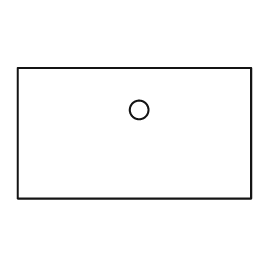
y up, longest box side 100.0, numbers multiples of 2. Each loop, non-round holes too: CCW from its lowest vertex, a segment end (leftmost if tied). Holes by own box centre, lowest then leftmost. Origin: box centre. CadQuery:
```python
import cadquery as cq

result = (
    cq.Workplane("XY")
    .moveTo(-50.0, -28.0)
    .lineTo(50.0, -28.0)
    .lineTo(50.0, 28.0)
    .lineTo(-50.0, 28.0)
    .close()
    .moveTo(2.0, 10.0)
    .circle(4.0)
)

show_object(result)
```